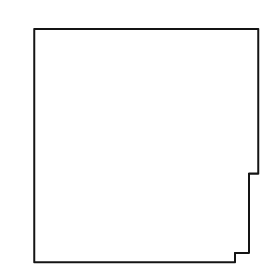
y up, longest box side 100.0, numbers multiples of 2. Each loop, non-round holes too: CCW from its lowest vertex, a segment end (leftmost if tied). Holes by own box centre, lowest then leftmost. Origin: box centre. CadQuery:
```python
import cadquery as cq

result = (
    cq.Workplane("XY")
    .moveTo(-48.0, -50.0)
    .lineTo(38.0, -50.0)
    .lineTo(38.0, -46.0)
    .lineTo(44.0, -46.0)
    .lineTo(44.0, -12.0)
    .lineTo(48.0, -12.0)
    .lineTo(48.0, 50.0)
    .lineTo(-48.0, 50.0)
    .close()
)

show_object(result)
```